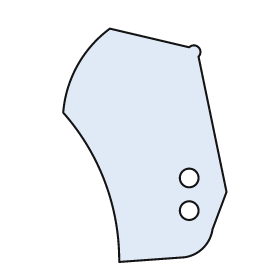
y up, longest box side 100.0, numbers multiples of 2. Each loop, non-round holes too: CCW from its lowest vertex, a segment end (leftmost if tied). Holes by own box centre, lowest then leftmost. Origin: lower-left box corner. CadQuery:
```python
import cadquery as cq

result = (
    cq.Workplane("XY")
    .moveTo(24.0, 0.0)
    .lineTo(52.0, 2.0)
    .threePointArc((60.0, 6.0), (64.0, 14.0))
    .lineTo(70.0, 30.0)
    .lineTo(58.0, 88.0)
    .threePointArc((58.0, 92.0), (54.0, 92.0))
    .lineTo(20.0, 100.0)
    .threePointArc((6.0, 84.0), (0.0, 64.0))
    .threePointArc((18.0, 34.0), (24.0, 0.0))
    .close()
    .moveTo(54.0, 22.0)
    .circle(4.0)
    .moveTo(54.0, 36.0)
    .circle(4.0)
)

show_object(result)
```